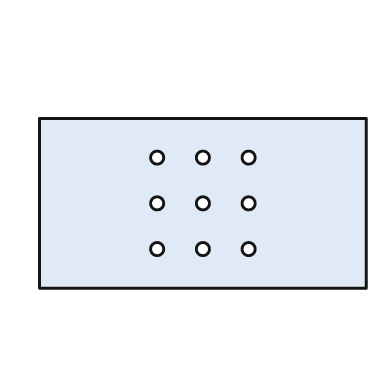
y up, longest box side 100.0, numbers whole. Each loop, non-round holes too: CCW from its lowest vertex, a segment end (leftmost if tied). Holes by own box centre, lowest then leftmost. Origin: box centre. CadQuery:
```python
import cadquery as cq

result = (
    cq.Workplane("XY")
    .moveTo(-50.0, -26.0)
    .lineTo(50.0, -26.0)
    .lineTo(50.0, 26.0)
    .lineTo(-50.0, 26.0)
    .close()
    .moveTo(-14.0, -14.0)
    .circle(2.0)
    .moveTo(0.0, -14.0)
    .circle(2.0)
    .moveTo(14.0, -14.0)
    .circle(2.0)
    .moveTo(-14.0, 0.0)
    .circle(2.0)
    .moveTo(0.0, 0.0)
    .circle(2.0)
    .moveTo(14.0, 0.0)
    .circle(2.0)
    .moveTo(-14.0, 14.0)
    .circle(2.0)
    .moveTo(0.0, 14.0)
    .circle(2.0)
    .moveTo(14.0, 14.0)
    .circle(2.0)
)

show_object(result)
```